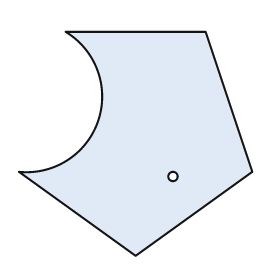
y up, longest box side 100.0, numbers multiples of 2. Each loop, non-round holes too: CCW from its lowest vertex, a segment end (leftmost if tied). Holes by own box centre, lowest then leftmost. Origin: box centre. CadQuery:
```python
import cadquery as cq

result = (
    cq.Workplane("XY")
    .moveTo(0.0, -48.0)
    .lineTo(50.0, -12.0)
    .lineTo(30.0, 48.0)
    .lineTo(-30.0, 48.0)
    .threePointArc((-16.0, 10.0), (-50.0, -12.0))
    .close()
    .moveTo(16.0, -14.0)
    .circle(2.0)
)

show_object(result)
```